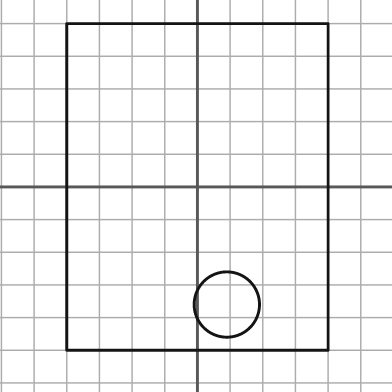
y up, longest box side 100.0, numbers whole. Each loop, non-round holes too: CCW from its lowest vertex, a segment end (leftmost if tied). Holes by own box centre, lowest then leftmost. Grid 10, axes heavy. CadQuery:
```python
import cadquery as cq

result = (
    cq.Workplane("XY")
    .moveTo(-40.0, -50.0)
    .lineTo(40.0, -50.0)
    .lineTo(40.0, 50.0)
    .lineTo(-40.0, 50.0)
    .close()
    .moveTo(9.0, -36.0)
    .circle(10.0)
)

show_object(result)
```